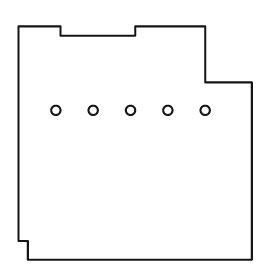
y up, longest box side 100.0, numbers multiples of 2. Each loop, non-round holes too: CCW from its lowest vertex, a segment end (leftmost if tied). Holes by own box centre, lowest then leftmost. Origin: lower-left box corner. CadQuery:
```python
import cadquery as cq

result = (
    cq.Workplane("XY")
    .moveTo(4.0, 0.0)
    .lineTo(100.0, 0.0)
    .lineTo(100.0, 76.0)
    .lineTo(80.0, 76.0)
    .lineTo(80.0, 100.0)
    .lineTo(50.0, 100.0)
    .lineTo(50.0, 96.0)
    .lineTo(18.0, 96.0)
    .lineTo(18.0, 100.0)
    .lineTo(0.0, 100.0)
    .lineTo(0.0, 8.0)
    .lineTo(4.0, 8.0)
    .close()
    .moveTo(16.0, 64.0)
    .circle(2.0)
    .moveTo(32.0, 64.0)
    .circle(2.0)
    .moveTo(48.0, 64.0)
    .circle(2.0)
    .moveTo(64.0, 64.0)
    .circle(2.0)
    .moveTo(80.0, 64.0)
    .circle(2.0)
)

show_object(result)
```